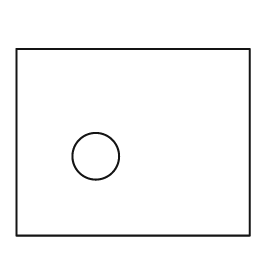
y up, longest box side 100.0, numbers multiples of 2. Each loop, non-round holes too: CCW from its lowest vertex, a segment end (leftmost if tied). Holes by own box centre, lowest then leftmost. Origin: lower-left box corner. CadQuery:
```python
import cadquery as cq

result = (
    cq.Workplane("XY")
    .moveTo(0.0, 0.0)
    .lineTo(100.0, 0.0)
    .lineTo(100.0, 80.0)
    .lineTo(0.0, 80.0)
    .close()
    .moveTo(34.0, 34.0)
    .circle(10.0)
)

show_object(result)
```